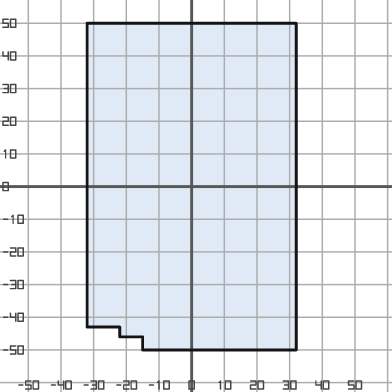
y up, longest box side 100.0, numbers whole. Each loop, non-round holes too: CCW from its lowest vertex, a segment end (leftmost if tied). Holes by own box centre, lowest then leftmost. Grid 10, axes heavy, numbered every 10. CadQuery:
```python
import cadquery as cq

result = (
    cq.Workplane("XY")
    .moveTo(-15.0, -50.0)
    .lineTo(32.0, -50.0)
    .lineTo(32.0, 50.0)
    .lineTo(-32.0, 50.0)
    .lineTo(-32.0, -43.0)
    .lineTo(-22.0, -43.0)
    .lineTo(-22.0, -46.0)
    .lineTo(-15.0, -46.0)
    .close()
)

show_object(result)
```